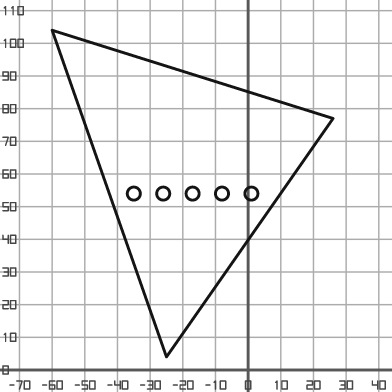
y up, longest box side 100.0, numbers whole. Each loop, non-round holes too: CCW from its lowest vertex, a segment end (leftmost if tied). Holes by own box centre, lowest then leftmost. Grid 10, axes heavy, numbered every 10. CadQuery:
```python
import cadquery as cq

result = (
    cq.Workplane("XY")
    .moveTo(-25.0, 4.0)
    .lineTo(26.0, 77.0)
    .lineTo(-60.0, 104.0)
    .close()
    .moveTo(-35.0, 54.0)
    .circle(2.0)
    .moveTo(-26.0, 54.0)
    .circle(2.0)
    .moveTo(-17.0, 54.0)
    .circle(2.0)
    .moveTo(-8.0, 54.0)
    .circle(2.0)
    .moveTo(1.0, 54.0)
    .circle(2.0)
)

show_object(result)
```